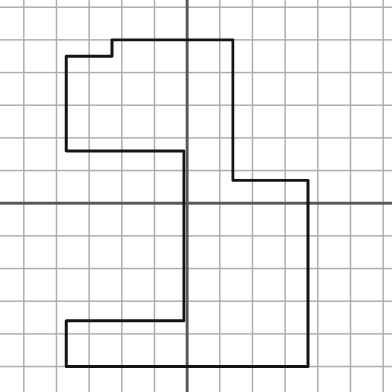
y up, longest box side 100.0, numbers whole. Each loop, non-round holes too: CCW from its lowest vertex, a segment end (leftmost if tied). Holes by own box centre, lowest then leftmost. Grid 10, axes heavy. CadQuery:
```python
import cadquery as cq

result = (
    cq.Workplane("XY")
    .moveTo(-37.0, -50.0)
    .lineTo(37.0, -50.0)
    .lineTo(37.0, 7.0)
    .lineTo(14.0, 7.0)
    .lineTo(14.0, 50.0)
    .lineTo(-23.0, 50.0)
    .lineTo(-23.0, 45.0)
    .lineTo(-37.0, 45.0)
    .lineTo(-37.0, 16.0)
    .lineTo(-1.0, 16.0)
    .lineTo(-1.0, -36.0)
    .lineTo(-37.0, -36.0)
    .close()
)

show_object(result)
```